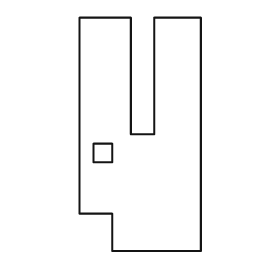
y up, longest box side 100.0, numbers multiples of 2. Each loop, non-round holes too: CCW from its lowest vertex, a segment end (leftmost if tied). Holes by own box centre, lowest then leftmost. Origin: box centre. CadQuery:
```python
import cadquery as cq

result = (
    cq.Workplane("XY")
    .moveTo(-12.0, -50.0)
    .lineTo(26.0, -50.0)
    .lineTo(26.0, 50.0)
    .lineTo(6.0, 50.0)
    .lineTo(6.0, 0.0)
    .lineTo(-4.0, 0.0)
    .lineTo(-4.0, 50.0)
    .lineTo(-26.0, 50.0)
    .lineTo(-26.0, -34.0)
    .lineTo(-12.0, -34.0)
    .close()
    .moveTo(-20.0, -12.0)
    .lineTo(-12.0, -12.0)
    .lineTo(-12.0, -4.0)
    .lineTo(-20.0, -4.0)
    .close()
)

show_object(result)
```